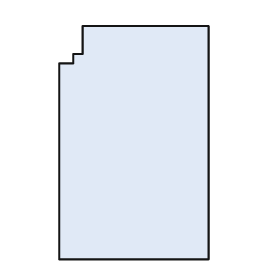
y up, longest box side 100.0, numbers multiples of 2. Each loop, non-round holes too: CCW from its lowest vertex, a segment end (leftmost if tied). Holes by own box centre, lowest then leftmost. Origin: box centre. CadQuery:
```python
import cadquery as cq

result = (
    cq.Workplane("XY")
    .moveTo(-32.0, -50.0)
    .lineTo(32.0, -50.0)
    .lineTo(32.0, 50.0)
    .lineTo(-22.0, 50.0)
    .lineTo(-22.0, 38.0)
    .lineTo(-26.0, 38.0)
    .lineTo(-26.0, 34.0)
    .lineTo(-32.0, 34.0)
    .close()
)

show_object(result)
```